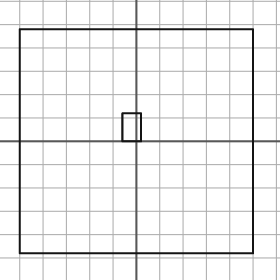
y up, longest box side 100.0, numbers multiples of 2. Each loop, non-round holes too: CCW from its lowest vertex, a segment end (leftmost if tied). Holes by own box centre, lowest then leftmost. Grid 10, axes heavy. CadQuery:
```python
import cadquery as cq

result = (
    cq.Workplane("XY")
    .moveTo(-50.0, -48.0)
    .lineTo(50.0, -48.0)
    .lineTo(50.0, 48.0)
    .lineTo(-50.0, 48.0)
    .close()
    .moveTo(-6.0, 0.0)
    .lineTo(2.0, 0.0)
    .lineTo(2.0, 12.0)
    .lineTo(-6.0, 12.0)
    .close()
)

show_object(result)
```